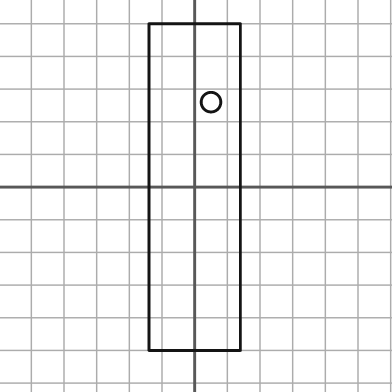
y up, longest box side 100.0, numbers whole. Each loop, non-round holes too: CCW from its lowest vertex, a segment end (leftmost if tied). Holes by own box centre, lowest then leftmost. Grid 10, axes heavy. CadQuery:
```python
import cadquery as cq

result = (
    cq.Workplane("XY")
    .moveTo(-14.0, -50.0)
    .lineTo(14.0, -50.0)
    .lineTo(14.0, 50.0)
    .lineTo(-14.0, 50.0)
    .close()
    .moveTo(5.0, 26.0)
    .circle(3.0)
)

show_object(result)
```